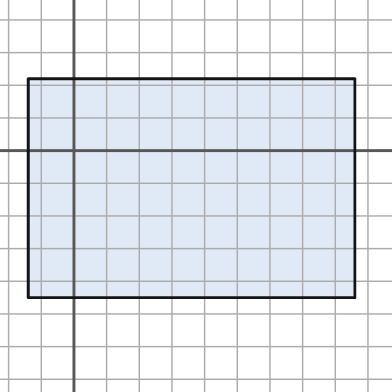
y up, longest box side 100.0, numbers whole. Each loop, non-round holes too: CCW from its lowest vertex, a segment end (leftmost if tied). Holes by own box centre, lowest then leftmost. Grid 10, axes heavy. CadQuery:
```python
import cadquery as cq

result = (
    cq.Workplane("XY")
    .moveTo(-14.0, -45.0)
    .lineTo(86.0, -45.0)
    .lineTo(86.0, 22.0)
    .lineTo(-14.0, 22.0)
    .close()
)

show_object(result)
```